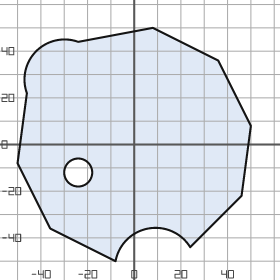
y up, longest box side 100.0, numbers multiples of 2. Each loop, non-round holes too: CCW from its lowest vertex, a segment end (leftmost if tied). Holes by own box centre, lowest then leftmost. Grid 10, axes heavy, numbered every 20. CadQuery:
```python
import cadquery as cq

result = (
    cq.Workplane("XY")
    .moveTo(-8.0, -50.0)
    .threePointArc((6.0, -36.0), (24.0, -44.0))
    .lineTo(46.0, -22.0)
    .lineTo(50.0, 8.0)
    .lineTo(36.0, 36.0)
    .lineTo(8.0, 50.0)
    .lineTo(-24.0, 44.0)
    .threePointArc((-42.0, 40.0), (-46.0, 22.0))
    .lineTo(-50.0, -8.0)
    .lineTo(-36.0, -36.0)
    .close()
    .moveTo(-24.0, -12.0)
    .circle(6.0)
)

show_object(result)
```